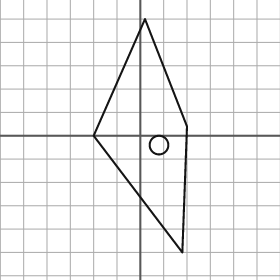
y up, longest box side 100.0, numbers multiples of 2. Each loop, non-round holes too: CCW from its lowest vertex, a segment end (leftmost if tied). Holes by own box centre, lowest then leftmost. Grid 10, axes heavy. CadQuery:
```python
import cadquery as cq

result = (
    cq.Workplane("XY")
    .moveTo(18.0, -50.0)
    .lineTo(20.0, 4.0)
    .lineTo(2.0, 50.0)
    .lineTo(-20.0, 0.0)
    .close()
    .moveTo(8.0, -4.0)
    .circle(4.0)
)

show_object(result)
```